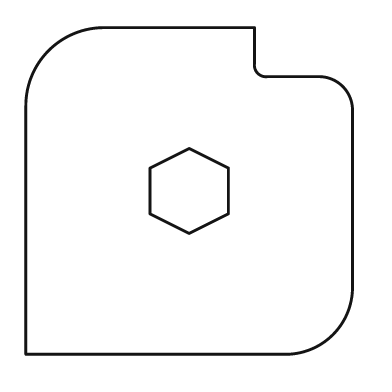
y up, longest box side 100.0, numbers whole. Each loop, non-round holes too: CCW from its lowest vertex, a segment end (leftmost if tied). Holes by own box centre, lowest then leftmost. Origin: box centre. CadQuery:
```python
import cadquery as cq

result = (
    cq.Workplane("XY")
    .moveTo(-50.0, -50.0)
    .lineTo(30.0, -50.0)
    .threePointArc((44.0, -44.0), (50.0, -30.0))
    .lineTo(50.0, 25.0)
    .threePointArc((47.0, 32.0), (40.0, 35.0))
    .lineTo(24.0, 35.0)
    .threePointArc((21.0, 36.0), (20.0, 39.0))
    .lineTo(20.0, 50.0)
    .lineTo(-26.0, 50.0)
    .threePointArc((-43.0, 43.0), (-50.0, 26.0))
    .close()
    .moveTo(0.0, -13.0)
    .lineTo(12.0, -7.0)
    .lineTo(12.0, 7.0)
    .lineTo(0.0, 13.0)
    .lineTo(-12.0, 7.0)
    .lineTo(-12.0, -7.0)
    .close()
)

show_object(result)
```